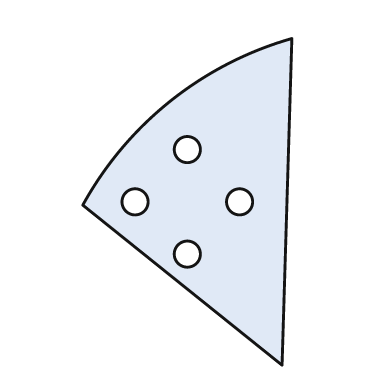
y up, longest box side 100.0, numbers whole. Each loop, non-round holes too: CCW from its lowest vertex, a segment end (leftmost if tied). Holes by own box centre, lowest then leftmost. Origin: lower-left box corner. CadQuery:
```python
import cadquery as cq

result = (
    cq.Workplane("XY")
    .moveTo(61.0, 0.0)
    .lineTo(64.0, 100.0)
    .threePointArc((27.0, 81.0), (0.0, 49.0))
    .close()
    .moveTo(32.0, 34.0)
    .circle(4.0)
    .moveTo(16.0, 50.0)
    .circle(4.0)
    .moveTo(48.0, 50.0)
    .circle(4.0)
    .moveTo(32.0, 66.0)
    .circle(4.0)
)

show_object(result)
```